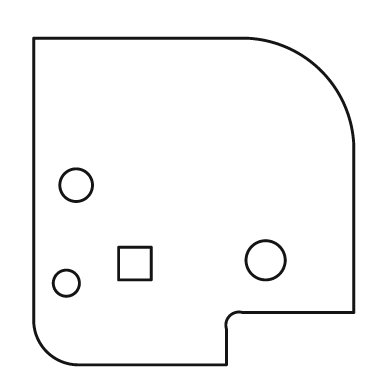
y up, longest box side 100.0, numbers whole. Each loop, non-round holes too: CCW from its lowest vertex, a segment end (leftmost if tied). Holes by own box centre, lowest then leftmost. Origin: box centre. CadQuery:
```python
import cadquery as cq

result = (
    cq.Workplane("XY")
    .moveTo(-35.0, -50.0)
    .lineTo(10.0, -50.0)
    .lineTo(10.0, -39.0)
    .threePointArc((11.0, -35.0), (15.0, -34.0))
    .lineTo(49.0, -34.0)
    .lineTo(49.0, 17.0)
    .threePointArc((39.0, 40.0), (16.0, 50.0))
    .lineTo(-49.0, 50.0)
    .lineTo(-49.0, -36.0)
    .threePointArc((-45.0, -46.0), (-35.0, -50.0))
    .close()
    .moveTo(-39.0, -25.0)
    .circle(4.0)
    .moveTo(-23.0, -24.0)
    .lineTo(-13.0, -24.0)
    .lineTo(-13.0, -14.0)
    .lineTo(-23.0, -14.0)
    .close()
    .moveTo(22.0, -18.0)
    .circle(6.0)
    .moveTo(-36.0, 5.0)
    .circle(5.0)
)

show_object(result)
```